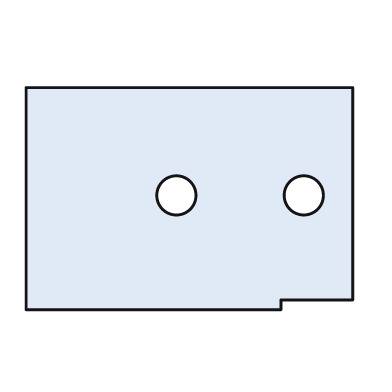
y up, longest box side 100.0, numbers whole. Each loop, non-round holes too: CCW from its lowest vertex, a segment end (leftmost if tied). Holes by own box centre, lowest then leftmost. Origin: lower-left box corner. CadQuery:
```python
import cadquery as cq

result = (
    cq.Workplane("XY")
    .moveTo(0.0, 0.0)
    .lineTo(78.0, 0.0)
    .lineTo(78.0, 3.0)
    .lineTo(100.0, 3.0)
    .lineTo(100.0, 68.0)
    .lineTo(0.0, 68.0)
    .close()
    .moveTo(46.0, 35.0)
    .circle(6.0)
    .moveTo(85.0, 35.0)
    .circle(6.0)
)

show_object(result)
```